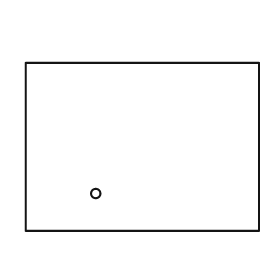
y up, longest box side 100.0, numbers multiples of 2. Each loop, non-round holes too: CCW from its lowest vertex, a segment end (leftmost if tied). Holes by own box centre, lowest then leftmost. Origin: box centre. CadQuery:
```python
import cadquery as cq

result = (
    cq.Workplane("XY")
    .moveTo(-50.0, -36.0)
    .lineTo(50.0, -36.0)
    .lineTo(50.0, 36.0)
    .lineTo(-50.0, 36.0)
    .close()
    .moveTo(-20.0, -20.0)
    .circle(2.0)
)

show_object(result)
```